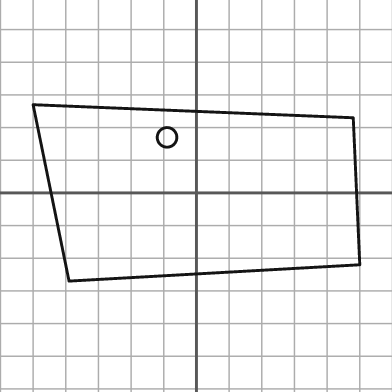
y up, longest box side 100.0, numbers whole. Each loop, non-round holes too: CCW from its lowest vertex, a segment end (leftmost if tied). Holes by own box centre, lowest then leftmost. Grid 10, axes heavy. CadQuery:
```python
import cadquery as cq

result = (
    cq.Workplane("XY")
    .moveTo(-39.0, -27.0)
    .lineTo(50.0, -22.0)
    .lineTo(48.0, 23.0)
    .lineTo(-50.0, 27.0)
    .close()
    .moveTo(-9.0, 17.0)
    .circle(3.0)
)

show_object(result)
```